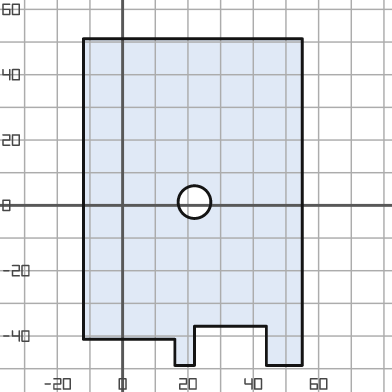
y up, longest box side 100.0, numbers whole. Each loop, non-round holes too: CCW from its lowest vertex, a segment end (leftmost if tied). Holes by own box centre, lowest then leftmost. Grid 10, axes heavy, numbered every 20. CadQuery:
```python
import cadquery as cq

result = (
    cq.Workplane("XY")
    .moveTo(16.0, -49.0)
    .lineTo(22.0, -49.0)
    .lineTo(22.0, -37.0)
    .lineTo(44.0, -37.0)
    .lineTo(44.0, -49.0)
    .lineTo(55.0, -49.0)
    .lineTo(55.0, 51.0)
    .lineTo(-12.0, 51.0)
    .lineTo(-12.0, -41.0)
    .lineTo(16.0, -41.0)
    .close()
    .moveTo(22.0, 1.0)
    .circle(5.0)
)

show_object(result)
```